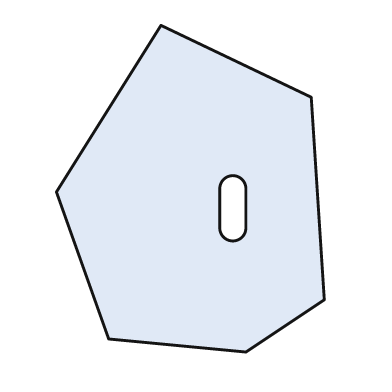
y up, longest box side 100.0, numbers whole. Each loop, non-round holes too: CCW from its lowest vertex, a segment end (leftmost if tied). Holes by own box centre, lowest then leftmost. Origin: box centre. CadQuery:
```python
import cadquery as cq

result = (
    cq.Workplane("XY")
    .moveTo(17.0, -50.0)
    .lineTo(41.0, -34.0)
    .lineTo(37.0, 28.0)
    .lineTo(-9.0, 50.0)
    .lineTo(-41.0, -1.0)
    .lineTo(-25.0, -46.0)
    .close()
    .moveTo(9.0, -12.0)
    .threePointArc((13.0, -16.0), (17.0, -12.0))
    .lineTo(17.0, 0.0)
    .threePointArc((13.0, 4.0), (9.0, 0.0))
    .close()
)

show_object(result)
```